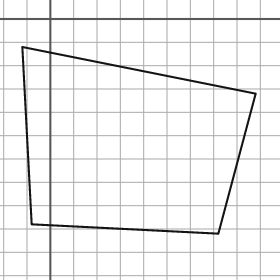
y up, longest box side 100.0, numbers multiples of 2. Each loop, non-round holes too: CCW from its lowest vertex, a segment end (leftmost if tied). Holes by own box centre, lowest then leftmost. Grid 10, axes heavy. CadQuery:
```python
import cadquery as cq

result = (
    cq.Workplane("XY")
    .moveTo(72.0, -92.0)
    .lineTo(88.0, -32.0)
    .lineTo(-12.0, -12.0)
    .lineTo(-8.0, -88.0)
    .close()
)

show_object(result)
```